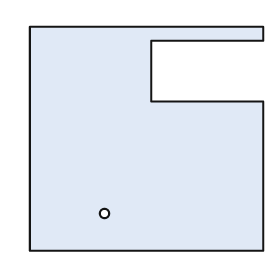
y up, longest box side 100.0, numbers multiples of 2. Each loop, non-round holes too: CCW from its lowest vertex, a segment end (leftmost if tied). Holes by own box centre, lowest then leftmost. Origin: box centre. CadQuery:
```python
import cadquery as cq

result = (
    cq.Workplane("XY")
    .moveTo(-50.0, -48.0)
    .lineTo(50.0, -48.0)
    .lineTo(50.0, 16.0)
    .lineTo(2.0, 16.0)
    .lineTo(2.0, 42.0)
    .lineTo(50.0, 42.0)
    .lineTo(50.0, 48.0)
    .lineTo(-50.0, 48.0)
    .close()
    .moveTo(-18.0, -32.0)
    .circle(2.0)
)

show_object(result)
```